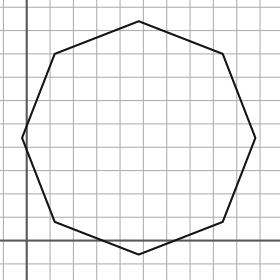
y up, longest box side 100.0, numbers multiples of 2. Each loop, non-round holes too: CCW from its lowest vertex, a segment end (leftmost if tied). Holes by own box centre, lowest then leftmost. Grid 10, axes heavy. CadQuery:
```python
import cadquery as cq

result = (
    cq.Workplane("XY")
    .moveTo(48.0, -6.0)
    .lineTo(84.0, 8.0)
    .lineTo(98.0, 44.0)
    .lineTo(84.0, 80.0)
    .lineTo(48.0, 94.0)
    .lineTo(12.0, 80.0)
    .lineTo(-2.0, 44.0)
    .lineTo(12.0, 8.0)
    .close()
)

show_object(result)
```